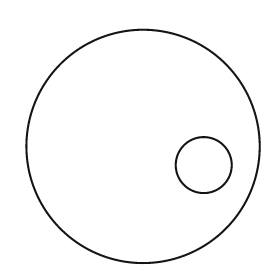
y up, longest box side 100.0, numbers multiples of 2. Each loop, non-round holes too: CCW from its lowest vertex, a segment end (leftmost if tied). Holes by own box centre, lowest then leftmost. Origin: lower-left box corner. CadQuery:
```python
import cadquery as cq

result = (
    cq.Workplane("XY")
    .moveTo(50.0, 50.0)
    .circle(50.0)
    .moveTo(76.0, 42.0)
    .circle(12.0)
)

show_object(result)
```